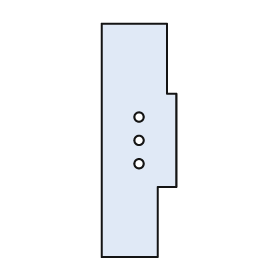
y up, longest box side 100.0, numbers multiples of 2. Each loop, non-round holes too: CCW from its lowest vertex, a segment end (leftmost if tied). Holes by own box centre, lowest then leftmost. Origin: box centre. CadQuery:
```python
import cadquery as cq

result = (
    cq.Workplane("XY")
    .moveTo(-16.0, -50.0)
    .lineTo(8.0, -50.0)
    .lineTo(8.0, -20.0)
    .lineTo(16.0, -20.0)
    .lineTo(16.0, 20.0)
    .lineTo(12.0, 20.0)
    .lineTo(12.0, 50.0)
    .lineTo(-16.0, 50.0)
    .close()
    .moveTo(0.0, -10.0)
    .circle(2.0)
    .moveTo(0.0, 0.0)
    .circle(2.0)
    .moveTo(0.0, 10.0)
    .circle(2.0)
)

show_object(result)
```